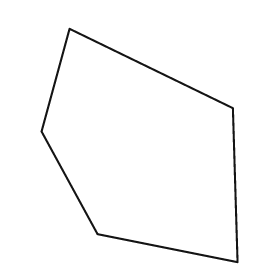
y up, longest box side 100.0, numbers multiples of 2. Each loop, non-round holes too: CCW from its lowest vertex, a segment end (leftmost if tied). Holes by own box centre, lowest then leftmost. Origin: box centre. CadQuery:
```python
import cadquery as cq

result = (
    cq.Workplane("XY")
    .moveTo(42.0, -50.0)
    .lineTo(40.0, 16.0)
    .lineTo(-30.0, 50.0)
    .lineTo(-42.0, 6.0)
    .lineTo(-18.0, -38.0)
    .close()
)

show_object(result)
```